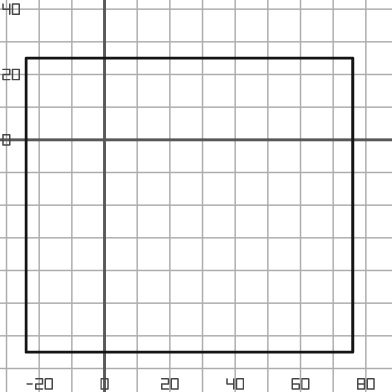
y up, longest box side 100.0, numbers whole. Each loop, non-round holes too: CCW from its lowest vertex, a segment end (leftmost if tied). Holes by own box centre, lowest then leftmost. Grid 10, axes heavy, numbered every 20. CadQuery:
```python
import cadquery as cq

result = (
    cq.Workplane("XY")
    .moveTo(-24.0, -65.0)
    .lineTo(76.0, -65.0)
    .lineTo(76.0, 25.0)
    .lineTo(-24.0, 25.0)
    .close()
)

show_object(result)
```